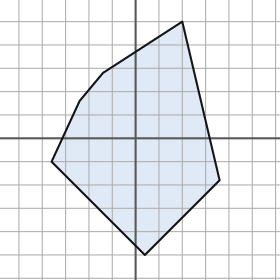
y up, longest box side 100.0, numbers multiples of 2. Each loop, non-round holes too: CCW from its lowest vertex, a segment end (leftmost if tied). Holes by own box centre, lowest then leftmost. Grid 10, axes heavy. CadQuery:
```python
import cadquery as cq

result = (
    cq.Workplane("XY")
    .moveTo(4.0, -50.0)
    .lineTo(36.0, -18.0)
    .lineTo(20.0, 50.0)
    .lineTo(-14.0, 28.0)
    .lineTo(-24.0, 16.0)
    .lineTo(-36.0, -10.0)
    .close()
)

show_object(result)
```